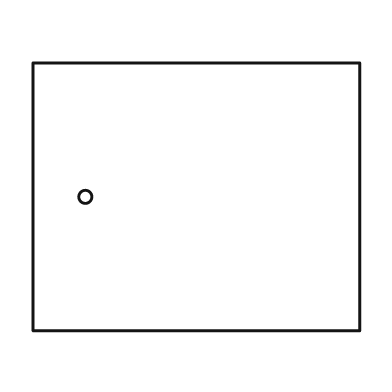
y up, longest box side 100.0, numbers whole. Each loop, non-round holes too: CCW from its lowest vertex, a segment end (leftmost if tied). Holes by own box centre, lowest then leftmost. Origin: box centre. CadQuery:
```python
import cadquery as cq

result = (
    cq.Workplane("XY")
    .moveTo(-50.0, -41.0)
    .lineTo(50.0, -41.0)
    .lineTo(50.0, 41.0)
    .lineTo(-50.0, 41.0)
    .close()
    .moveTo(-34.0, 0.0)
    .circle(2.0)
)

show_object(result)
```